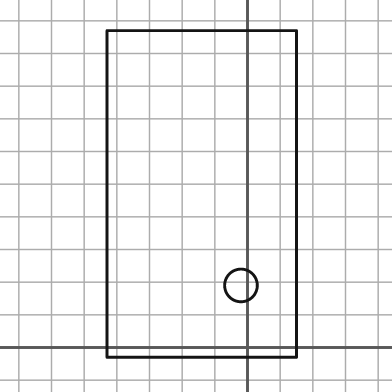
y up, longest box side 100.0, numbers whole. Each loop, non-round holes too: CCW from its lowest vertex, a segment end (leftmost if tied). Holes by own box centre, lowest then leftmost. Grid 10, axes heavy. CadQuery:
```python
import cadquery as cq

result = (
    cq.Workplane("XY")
    .moveTo(-43.0, -3.0)
    .lineTo(15.0, -3.0)
    .lineTo(15.0, 97.0)
    .lineTo(-43.0, 97.0)
    .close()
    .moveTo(-2.0, 19.0)
    .circle(5.0)
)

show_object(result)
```